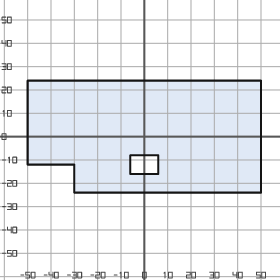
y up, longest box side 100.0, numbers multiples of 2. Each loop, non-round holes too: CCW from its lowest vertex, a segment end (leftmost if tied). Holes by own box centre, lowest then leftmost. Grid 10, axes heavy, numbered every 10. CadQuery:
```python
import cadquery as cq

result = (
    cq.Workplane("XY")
    .moveTo(-30.0, -24.0)
    .lineTo(50.0, -24.0)
    .lineTo(50.0, 24.0)
    .lineTo(-50.0, 24.0)
    .lineTo(-50.0, -12.0)
    .lineTo(-30.0, -12.0)
    .close()
    .moveTo(-6.0, -16.0)
    .lineTo(6.0, -16.0)
    .lineTo(6.0, -8.0)
    .lineTo(-6.0, -8.0)
    .close()
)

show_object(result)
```